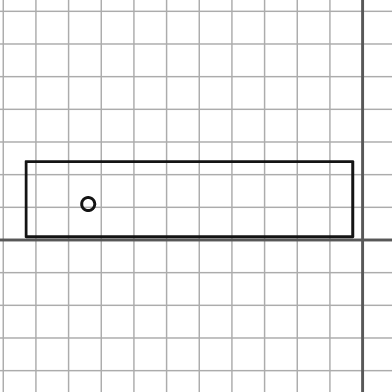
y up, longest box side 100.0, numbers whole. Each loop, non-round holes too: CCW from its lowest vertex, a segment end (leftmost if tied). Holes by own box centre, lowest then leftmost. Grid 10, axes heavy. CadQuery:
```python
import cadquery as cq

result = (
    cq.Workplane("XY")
    .moveTo(-103.0, 1.0)
    .lineTo(-3.0, 1.0)
    .lineTo(-3.0, 24.0)
    .lineTo(-103.0, 24.0)
    .close()
    .moveTo(-84.0, 11.0)
    .circle(2.0)
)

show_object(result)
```